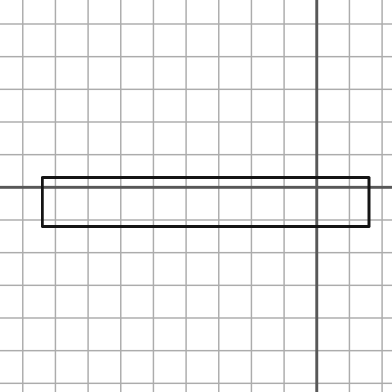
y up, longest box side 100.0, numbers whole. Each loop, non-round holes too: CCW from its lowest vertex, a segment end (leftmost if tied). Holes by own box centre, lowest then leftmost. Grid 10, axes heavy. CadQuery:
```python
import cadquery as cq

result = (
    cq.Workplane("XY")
    .moveTo(-84.0, -12.0)
    .lineTo(16.0, -12.0)
    .lineTo(16.0, 3.0)
    .lineTo(-84.0, 3.0)
    .close()
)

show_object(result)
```